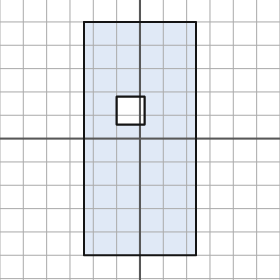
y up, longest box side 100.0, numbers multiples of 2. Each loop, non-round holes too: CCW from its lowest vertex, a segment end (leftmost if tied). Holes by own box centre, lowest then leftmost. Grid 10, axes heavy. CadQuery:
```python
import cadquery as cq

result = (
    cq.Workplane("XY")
    .moveTo(-24.0, -50.0)
    .lineTo(24.0, -50.0)
    .lineTo(24.0, 50.0)
    .lineTo(-24.0, 50.0)
    .close()
    .moveTo(-10.0, 6.0)
    .lineTo(2.0, 6.0)
    .lineTo(2.0, 18.0)
    .lineTo(-10.0, 18.0)
    .close()
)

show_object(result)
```